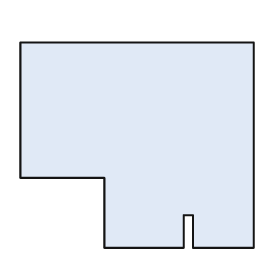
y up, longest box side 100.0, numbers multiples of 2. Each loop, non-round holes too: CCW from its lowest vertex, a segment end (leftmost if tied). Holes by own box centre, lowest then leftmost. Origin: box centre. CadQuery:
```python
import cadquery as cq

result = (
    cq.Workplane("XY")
    .moveTo(-14.0, -44.0)
    .lineTo(20.0, -44.0)
    .lineTo(20.0, -30.0)
    .lineTo(24.0, -30.0)
    .lineTo(24.0, -44.0)
    .lineTo(50.0, -44.0)
    .lineTo(50.0, 44.0)
    .lineTo(-50.0, 44.0)
    .lineTo(-50.0, -14.0)
    .lineTo(-14.0, -14.0)
    .close()
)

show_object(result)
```